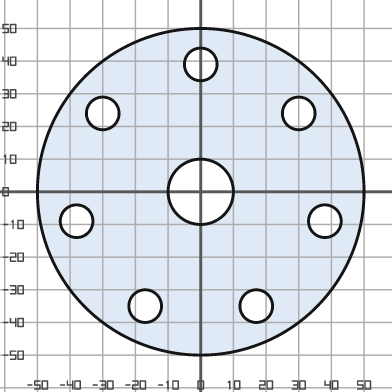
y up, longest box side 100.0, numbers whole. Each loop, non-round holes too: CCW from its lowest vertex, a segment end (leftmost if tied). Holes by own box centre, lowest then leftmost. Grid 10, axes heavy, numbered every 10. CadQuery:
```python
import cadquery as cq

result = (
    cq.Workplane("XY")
    .moveTo(0.0, 0.0)
    .circle(50.0)
    .moveTo(-17.0, -35.0)
    .circle(5.0)
    .moveTo(17.0, -35.0)
    .circle(5.0)
    .moveTo(-38.0, -9.0)
    .circle(5.0)
    .moveTo(38.0, -9.0)
    .circle(5.0)
    .moveTo(0.0, 0.0)
    .circle(10.0)
    .moveTo(-30.0, 24.0)
    .circle(5.0)
    .moveTo(30.0, 24.0)
    .circle(5.0)
    .moveTo(0.0, 39.0)
    .circle(5.0)
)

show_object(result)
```